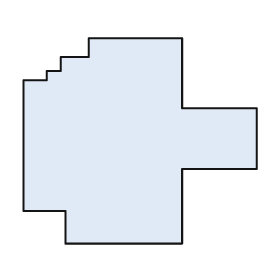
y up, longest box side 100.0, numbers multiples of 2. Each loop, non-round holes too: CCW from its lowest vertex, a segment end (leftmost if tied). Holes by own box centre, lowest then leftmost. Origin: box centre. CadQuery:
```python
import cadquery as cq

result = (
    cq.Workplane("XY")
    .moveTo(-32.0, -44.0)
    .lineTo(18.0, -44.0)
    .lineTo(18.0, -12.0)
    .lineTo(50.0, -12.0)
    .lineTo(50.0, 14.0)
    .lineTo(18.0, 14.0)
    .lineTo(18.0, 44.0)
    .lineTo(-22.0, 44.0)
    .lineTo(-22.0, 36.0)
    .lineTo(-34.0, 36.0)
    .lineTo(-34.0, 30.0)
    .lineTo(-40.0, 30.0)
    .lineTo(-40.0, 26.0)
    .lineTo(-50.0, 26.0)
    .lineTo(-50.0, -30.0)
    .lineTo(-32.0, -30.0)
    .close()
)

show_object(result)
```